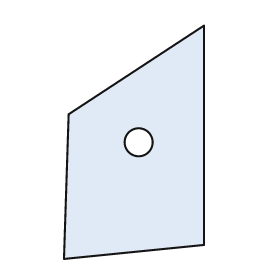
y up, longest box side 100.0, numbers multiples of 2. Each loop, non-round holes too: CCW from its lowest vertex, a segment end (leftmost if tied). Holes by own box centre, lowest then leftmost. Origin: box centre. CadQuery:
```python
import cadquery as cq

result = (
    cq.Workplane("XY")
    .moveTo(-30.0, -50.0)
    .lineTo(30.0, -44.0)
    .lineTo(30.0, 50.0)
    .lineTo(-28.0, 12.0)
    .close()
    .moveTo(2.0, 0.0)
    .circle(6.0)
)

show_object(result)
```